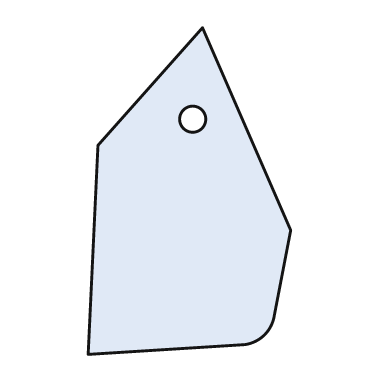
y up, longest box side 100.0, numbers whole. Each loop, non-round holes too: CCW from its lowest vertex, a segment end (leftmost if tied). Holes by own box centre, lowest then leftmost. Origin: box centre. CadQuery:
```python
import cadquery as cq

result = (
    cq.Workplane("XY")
    .moveTo(-31.0, -50.0)
    .lineTo(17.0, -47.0)
    .threePointArc((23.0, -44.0), (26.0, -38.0))
    .lineTo(31.0, -12.0)
    .lineTo(4.0, 50.0)
    .lineTo(-28.0, 14.0)
    .close()
    .moveTo(1.0, 22.0)
    .circle(4.0)
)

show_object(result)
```